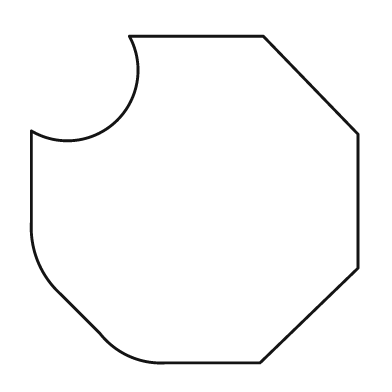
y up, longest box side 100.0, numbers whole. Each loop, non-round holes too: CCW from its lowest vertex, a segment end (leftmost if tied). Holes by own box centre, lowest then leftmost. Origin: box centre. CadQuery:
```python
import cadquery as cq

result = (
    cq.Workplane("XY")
    .moveTo(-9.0, -50.0)
    .lineTo(20.0, -50.0)
    .lineTo(50.0, -21.0)
    .lineTo(50.0, 20.0)
    .lineTo(21.0, 50.0)
    .lineTo(-20.0, 50.0)
    .threePointArc((-24.0, 24.0), (-50.0, 21.0))
    .lineTo(-50.0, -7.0)
    .threePointArc((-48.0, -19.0), (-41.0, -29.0))
    .lineTo(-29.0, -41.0)
    .threePointArc((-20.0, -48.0), (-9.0, -50.0))
    .close()
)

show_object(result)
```